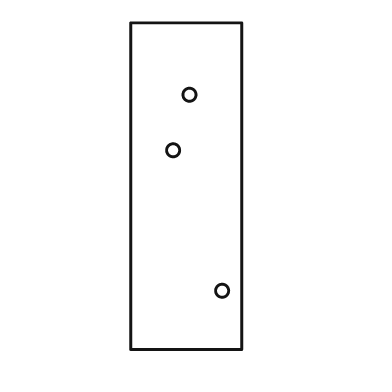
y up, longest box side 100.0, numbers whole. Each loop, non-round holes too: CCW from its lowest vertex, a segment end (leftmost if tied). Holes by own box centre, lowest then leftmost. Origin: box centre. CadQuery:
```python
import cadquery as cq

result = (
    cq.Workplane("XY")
    .moveTo(-17.0, -50.0)
    .lineTo(17.0, -50.0)
    .lineTo(17.0, 50.0)
    .lineTo(-17.0, 50.0)
    .close()
    .moveTo(11.0, -32.0)
    .circle(2.0)
    .moveTo(-4.0, 11.0)
    .circle(2.0)
    .moveTo(1.0, 28.0)
    .circle(2.0)
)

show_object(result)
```